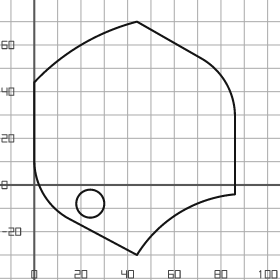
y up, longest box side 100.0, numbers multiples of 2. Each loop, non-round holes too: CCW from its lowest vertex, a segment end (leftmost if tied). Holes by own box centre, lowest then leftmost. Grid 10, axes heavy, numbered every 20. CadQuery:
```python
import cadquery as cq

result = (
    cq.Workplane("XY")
    .moveTo(44.0, -30.0)
    .threePointArc((62.0, -12.0), (86.0, -4.0))
    .lineTo(86.0, 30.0)
    .threePointArc((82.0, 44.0), (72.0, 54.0))
    .lineTo(44.0, 70.0)
    .threePointArc((20.0, 60.0), (0.0, 44.0))
    .lineTo(0.0, 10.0)
    .threePointArc((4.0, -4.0), (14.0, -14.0))
    .close()
    .moveTo(24.0, -8.0)
    .circle(6.0)
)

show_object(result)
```